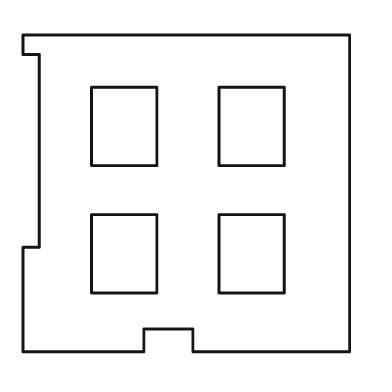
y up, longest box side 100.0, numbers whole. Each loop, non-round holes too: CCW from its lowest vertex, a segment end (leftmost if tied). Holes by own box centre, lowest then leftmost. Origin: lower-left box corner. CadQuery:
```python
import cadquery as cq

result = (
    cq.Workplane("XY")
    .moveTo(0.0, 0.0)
    .lineTo(37.0, 0.0)
    .lineTo(37.0, 7.0)
    .lineTo(52.0, 7.0)
    .lineTo(52.0, 0.0)
    .lineTo(100.0, 0.0)
    .lineTo(100.0, 97.0)
    .lineTo(0.0, 97.0)
    .lineTo(0.0, 91.0)
    .lineTo(5.0, 91.0)
    .lineTo(5.0, 32.0)
    .lineTo(0.0, 32.0)
    .close()
    .moveTo(21.0, 18.0)
    .lineTo(41.0, 18.0)
    .lineTo(41.0, 42.0)
    .lineTo(21.0, 42.0)
    .close()
    .moveTo(60.0, 18.0)
    .lineTo(80.0, 18.0)
    .lineTo(80.0, 42.0)
    .lineTo(60.0, 42.0)
    .close()
    .moveTo(21.0, 57.0)
    .lineTo(41.0, 57.0)
    .lineTo(41.0, 81.0)
    .lineTo(21.0, 81.0)
    .close()
    .moveTo(60.0, 57.0)
    .lineTo(80.0, 57.0)
    .lineTo(80.0, 81.0)
    .lineTo(60.0, 81.0)
    .close()
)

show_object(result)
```